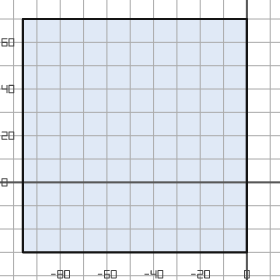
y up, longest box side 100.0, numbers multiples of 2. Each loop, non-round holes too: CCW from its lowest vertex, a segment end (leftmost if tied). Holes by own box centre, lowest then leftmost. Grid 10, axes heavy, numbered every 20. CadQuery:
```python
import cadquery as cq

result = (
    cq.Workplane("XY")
    .moveTo(-96.0, -30.0)
    .lineTo(0.0, -30.0)
    .lineTo(0.0, 70.0)
    .lineTo(-96.0, 70.0)
    .close()
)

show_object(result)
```